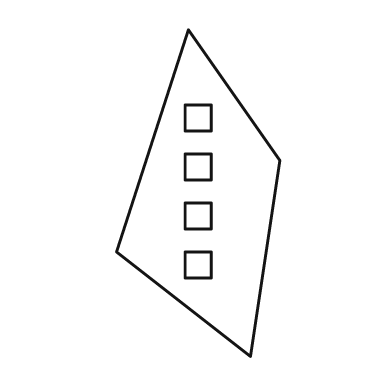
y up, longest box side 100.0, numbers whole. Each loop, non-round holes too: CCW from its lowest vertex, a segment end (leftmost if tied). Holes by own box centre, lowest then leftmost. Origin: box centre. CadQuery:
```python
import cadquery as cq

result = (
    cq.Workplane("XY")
    .moveTo(16.0, -50.0)
    .lineTo(25.0, 10.0)
    .lineTo(-3.0, 50.0)
    .lineTo(-25.0, -18.0)
    .close()
    .moveTo(-4.0, -26.0)
    .lineTo(4.0, -26.0)
    .lineTo(4.0, -18.0)
    .lineTo(-4.0, -18.0)
    .close()
    .moveTo(-4.0, -11.0)
    .lineTo(4.0, -11.0)
    .lineTo(4.0, -3.0)
    .lineTo(-4.0, -3.0)
    .close()
    .moveTo(-4.0, 4.0)
    .lineTo(4.0, 4.0)
    .lineTo(4.0, 12.0)
    .lineTo(-4.0, 12.0)
    .close()
    .moveTo(-4.0, 19.0)
    .lineTo(4.0, 19.0)
    .lineTo(4.0, 27.0)
    .lineTo(-4.0, 27.0)
    .close()
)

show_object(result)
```